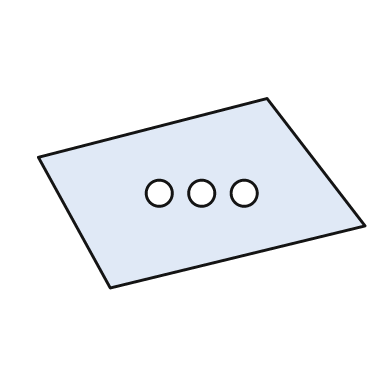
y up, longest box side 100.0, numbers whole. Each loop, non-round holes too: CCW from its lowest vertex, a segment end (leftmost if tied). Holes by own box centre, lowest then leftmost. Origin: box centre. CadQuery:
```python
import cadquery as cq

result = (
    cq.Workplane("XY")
    .moveTo(-28.0, -29.0)
    .lineTo(50.0, -10.0)
    .lineTo(20.0, 29.0)
    .lineTo(-50.0, 11.0)
    .close()
    .moveTo(-13.0, 0.0)
    .circle(4.0)
    .moveTo(0.0, 0.0)
    .circle(4.0)
    .moveTo(13.0, 0.0)
    .circle(4.0)
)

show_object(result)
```